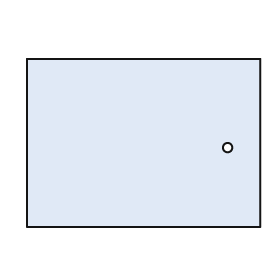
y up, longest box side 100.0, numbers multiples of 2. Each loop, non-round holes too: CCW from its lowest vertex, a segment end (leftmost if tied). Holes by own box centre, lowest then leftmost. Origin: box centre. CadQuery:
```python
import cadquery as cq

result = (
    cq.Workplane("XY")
    .moveTo(-50.0, -36.0)
    .lineTo(50.0, -36.0)
    .lineTo(50.0, 36.0)
    .lineTo(-50.0, 36.0)
    .close()
    .moveTo(36.0, -2.0)
    .circle(2.0)
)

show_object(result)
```